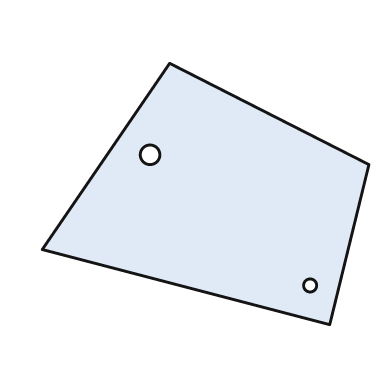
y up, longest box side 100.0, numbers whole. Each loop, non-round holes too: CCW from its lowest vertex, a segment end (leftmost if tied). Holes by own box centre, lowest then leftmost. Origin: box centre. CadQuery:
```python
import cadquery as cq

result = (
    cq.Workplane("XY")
    .moveTo(38.0, -40.0)
    .lineTo(50.0, 9.0)
    .lineTo(-11.0, 40.0)
    .lineTo(-50.0, -17.0)
    .close()
    .moveTo(32.0, -28.0)
    .circle(2.0)
    .moveTo(-17.0, 12.0)
    .circle(3.0)
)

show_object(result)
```